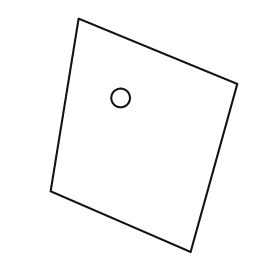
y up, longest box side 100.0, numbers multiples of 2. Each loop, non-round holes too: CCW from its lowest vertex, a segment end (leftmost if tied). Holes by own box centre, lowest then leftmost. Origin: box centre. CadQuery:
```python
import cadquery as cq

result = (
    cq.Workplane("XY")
    .moveTo(20.0, -50.0)
    .lineTo(40.0, 22.0)
    .lineTo(-28.0, 50.0)
    .lineTo(-40.0, -24.0)
    .close()
    .moveTo(-10.0, 16.0)
    .circle(4.0)
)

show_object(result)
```